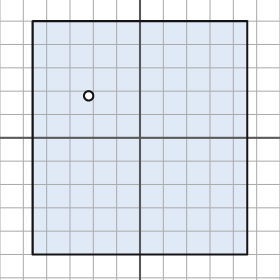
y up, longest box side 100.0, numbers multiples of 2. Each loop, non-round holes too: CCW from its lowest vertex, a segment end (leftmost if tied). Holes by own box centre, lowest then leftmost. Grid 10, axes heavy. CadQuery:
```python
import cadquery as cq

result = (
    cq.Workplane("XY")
    .moveTo(-46.0, -50.0)
    .lineTo(46.0, -50.0)
    .lineTo(46.0, 50.0)
    .lineTo(-46.0, 50.0)
    .close()
    .moveTo(-22.0, 18.0)
    .circle(2.0)
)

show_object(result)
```